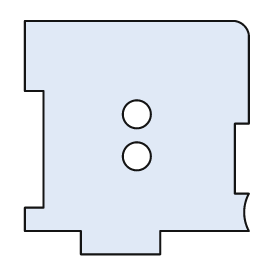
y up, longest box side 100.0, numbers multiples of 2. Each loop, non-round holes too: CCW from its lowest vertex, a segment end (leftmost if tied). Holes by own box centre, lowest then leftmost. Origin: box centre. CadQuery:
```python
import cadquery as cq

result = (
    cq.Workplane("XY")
    .moveTo(-24.0, -50.0)
    .lineTo(10.0, -50.0)
    .lineTo(10.0, -40.0)
    .lineTo(48.0, -40.0)
    .threePointArc((46.0, -32.0), (48.0, -24.0))
    .lineTo(42.0, -24.0)
    .lineTo(42.0, 6.0)
    .lineTo(48.0, 6.0)
    .lineTo(48.0, 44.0)
    .threePointArc((46.0, 48.0), (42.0, 50.0))
    .lineTo(-48.0, 50.0)
    .lineTo(-48.0, 20.0)
    .lineTo(-40.0, 20.0)
    .lineTo(-40.0, -30.0)
    .lineTo(-48.0, -30.0)
    .lineTo(-48.0, -40.0)
    .lineTo(-24.0, -40.0)
    .close()
    .moveTo(0.0, -8.0)
    .circle(6.0)
    .moveTo(0.0, 10.0)
    .circle(6.0)
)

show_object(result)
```